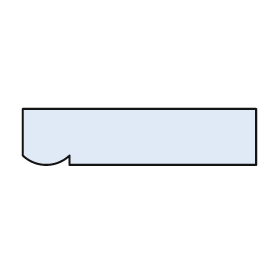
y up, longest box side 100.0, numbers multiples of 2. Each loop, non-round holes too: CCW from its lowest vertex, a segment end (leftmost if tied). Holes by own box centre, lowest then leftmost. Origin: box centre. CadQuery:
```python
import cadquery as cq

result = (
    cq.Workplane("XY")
    .moveTo(-30.0, -12.0)
    .lineTo(50.0, -12.0)
    .lineTo(50.0, 12.0)
    .lineTo(-50.0, 12.0)
    .lineTo(-50.0, -8.0)
    .threePointArc((-40.0, -12.0), (-30.0, -8.0))
    .close()
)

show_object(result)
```